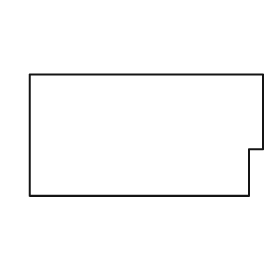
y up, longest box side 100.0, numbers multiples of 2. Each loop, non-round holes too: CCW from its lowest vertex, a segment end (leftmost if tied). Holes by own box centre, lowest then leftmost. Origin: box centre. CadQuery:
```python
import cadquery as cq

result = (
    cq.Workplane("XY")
    .moveTo(-50.0, -26.0)
    .lineTo(44.0, -26.0)
    .lineTo(44.0, -6.0)
    .lineTo(50.0, -6.0)
    .lineTo(50.0, 26.0)
    .lineTo(-50.0, 26.0)
    .close()
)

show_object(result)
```